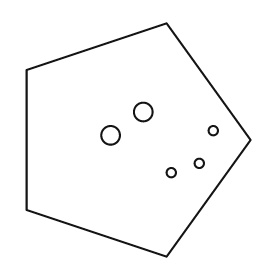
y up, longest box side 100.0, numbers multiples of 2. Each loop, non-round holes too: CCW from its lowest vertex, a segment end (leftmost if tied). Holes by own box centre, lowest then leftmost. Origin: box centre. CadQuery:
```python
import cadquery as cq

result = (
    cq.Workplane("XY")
    .moveTo(12.0, -50.0)
    .lineTo(48.0, 0.0)
    .lineTo(12.0, 50.0)
    .lineTo(-48.0, 30.0)
    .lineTo(-48.0, -30.0)
    .close()
    .moveTo(14.0, -14.0)
    .circle(2.0)
    .moveTo(26.0, -10.0)
    .circle(2.0)
    .moveTo(-12.0, 2.0)
    .circle(4.0)
    .moveTo(32.0, 4.0)
    .circle(2.0)
    .moveTo(2.0, 12.0)
    .circle(4.0)
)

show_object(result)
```